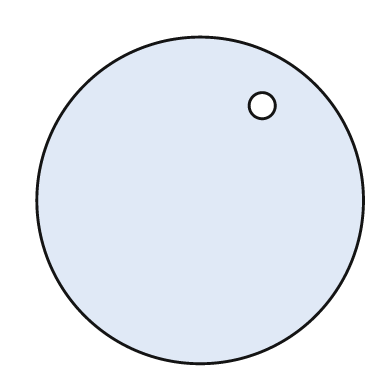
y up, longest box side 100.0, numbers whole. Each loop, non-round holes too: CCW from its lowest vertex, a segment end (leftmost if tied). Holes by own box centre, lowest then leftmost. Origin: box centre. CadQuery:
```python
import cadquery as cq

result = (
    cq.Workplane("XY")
    .moveTo(0.0, 0.0)
    .circle(50.0)
    .moveTo(19.0, 29.0)
    .circle(4.0)
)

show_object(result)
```